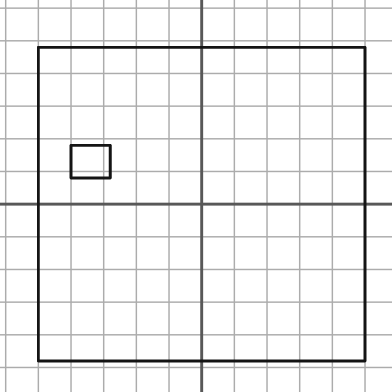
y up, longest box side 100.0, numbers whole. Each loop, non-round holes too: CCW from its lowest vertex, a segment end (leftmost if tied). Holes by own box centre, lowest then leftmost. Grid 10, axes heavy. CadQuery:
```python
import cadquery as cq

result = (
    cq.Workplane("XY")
    .moveTo(-50.0, -48.0)
    .lineTo(50.0, -48.0)
    .lineTo(50.0, 48.0)
    .lineTo(-50.0, 48.0)
    .close()
    .moveTo(-40.0, 8.0)
    .lineTo(-28.0, 8.0)
    .lineTo(-28.0, 18.0)
    .lineTo(-40.0, 18.0)
    .close()
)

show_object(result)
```